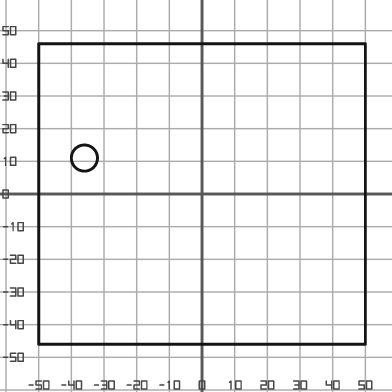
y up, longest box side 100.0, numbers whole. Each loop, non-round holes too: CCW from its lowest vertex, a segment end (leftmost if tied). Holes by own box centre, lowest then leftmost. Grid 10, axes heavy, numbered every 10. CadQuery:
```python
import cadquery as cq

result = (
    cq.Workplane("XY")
    .moveTo(-50.0, -46.0)
    .lineTo(50.0, -46.0)
    .lineTo(50.0, 46.0)
    .lineTo(-50.0, 46.0)
    .close()
    .moveTo(-36.0, 11.0)
    .circle(4.0)
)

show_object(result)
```